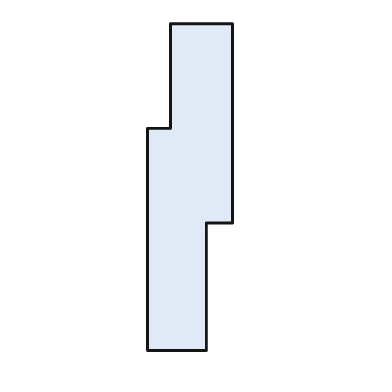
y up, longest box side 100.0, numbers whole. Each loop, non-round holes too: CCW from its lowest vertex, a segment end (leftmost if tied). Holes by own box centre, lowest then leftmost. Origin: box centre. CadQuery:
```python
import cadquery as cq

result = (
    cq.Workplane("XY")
    .moveTo(-13.0, -50.0)
    .lineTo(5.0, -50.0)
    .lineTo(5.0, -11.0)
    .lineTo(13.0, -11.0)
    .lineTo(13.0, 50.0)
    .lineTo(-6.0, 50.0)
    .lineTo(-6.0, 18.0)
    .lineTo(-13.0, 18.0)
    .close()
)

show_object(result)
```